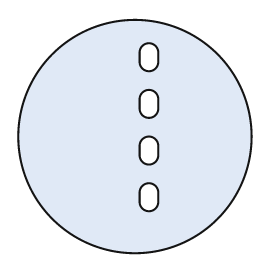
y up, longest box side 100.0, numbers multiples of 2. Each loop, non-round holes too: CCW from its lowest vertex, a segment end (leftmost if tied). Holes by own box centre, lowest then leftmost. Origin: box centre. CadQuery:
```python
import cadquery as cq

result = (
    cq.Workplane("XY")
    .moveTo(0.0, 0.0)
    .circle(50.0)
    .moveTo(2.0, -28.0)
    .threePointArc((6.0, -32.0), (10.0, -28.0))
    .lineTo(10.0, -24.0)
    .threePointArc((6.0, -20.0), (2.0, -24.0))
    .close()
    .moveTo(2.0, -8.0)
    .threePointArc((6.0, -12.0), (10.0, -8.0))
    .lineTo(10.0, -4.0)
    .threePointArc((6.0, 0.0), (2.0, -4.0))
    .close()
    .moveTo(2.0, 12.0)
    .threePointArc((6.0, 8.0), (10.0, 12.0))
    .lineTo(10.0, 16.0)
    .threePointArc((6.0, 20.0), (2.0, 16.0))
    .close()
    .moveTo(2.0, 32.0)
    .threePointArc((6.0, 28.0), (10.0, 32.0))
    .lineTo(10.0, 36.0)
    .threePointArc((6.0, 40.0), (2.0, 36.0))
    .close()
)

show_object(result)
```